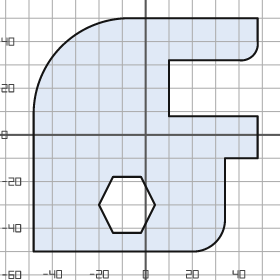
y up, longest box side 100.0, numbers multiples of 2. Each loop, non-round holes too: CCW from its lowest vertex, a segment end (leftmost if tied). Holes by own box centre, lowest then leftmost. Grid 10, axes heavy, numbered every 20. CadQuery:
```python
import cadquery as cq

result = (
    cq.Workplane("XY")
    .moveTo(-48.0, -50.0)
    .lineTo(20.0, -50.0)
    .threePointArc((30.0, -46.0), (34.0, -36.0))
    .lineTo(34.0, -10.0)
    .lineTo(48.0, -10.0)
    .lineTo(48.0, 8.0)
    .lineTo(10.0, 8.0)
    .lineTo(10.0, 32.0)
    .lineTo(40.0, 32.0)
    .threePointArc((46.0, 34.0), (48.0, 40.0))
    .lineTo(48.0, 50.0)
    .lineTo(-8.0, 50.0)
    .threePointArc((-36.0, 38.0), (-48.0, 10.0))
    .close()
    .moveTo(-14.0, -42.0)
    .lineTo(-2.0, -42.0)
    .lineTo(4.0, -30.0)
    .lineTo(-2.0, -18.0)
    .lineTo(-14.0, -18.0)
    .lineTo(-20.0, -30.0)
    .close()
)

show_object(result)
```